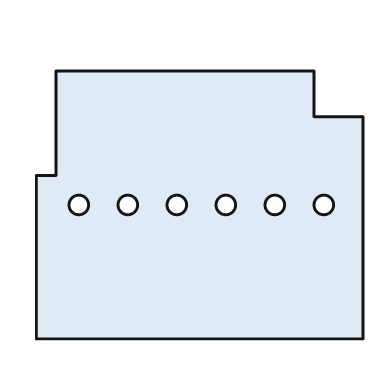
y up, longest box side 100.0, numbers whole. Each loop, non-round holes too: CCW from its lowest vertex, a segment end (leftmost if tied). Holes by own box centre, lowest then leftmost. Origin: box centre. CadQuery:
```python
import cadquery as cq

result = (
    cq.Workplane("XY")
    .moveTo(-50.0, -41.0)
    .lineTo(50.0, -41.0)
    .lineTo(50.0, 27.0)
    .lineTo(35.0, 27.0)
    .lineTo(35.0, 41.0)
    .lineTo(-44.0, 41.0)
    .lineTo(-44.0, 9.0)
    .lineTo(-50.0, 9.0)
    .close()
    .moveTo(-37.0, 0.0)
    .circle(3.0)
    .moveTo(-22.0, 0.0)
    .circle(3.0)
    .moveTo(-7.0, 0.0)
    .circle(3.0)
    .moveTo(8.0, 0.0)
    .circle(3.0)
    .moveTo(23.0, 0.0)
    .circle(3.0)
    .moveTo(38.0, 0.0)
    .circle(3.0)
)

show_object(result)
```